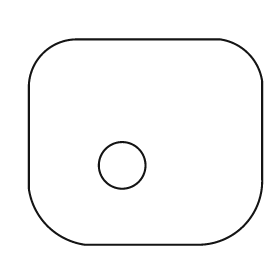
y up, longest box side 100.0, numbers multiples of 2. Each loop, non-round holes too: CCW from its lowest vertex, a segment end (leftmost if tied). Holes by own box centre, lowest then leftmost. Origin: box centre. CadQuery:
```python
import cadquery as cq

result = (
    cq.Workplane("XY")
    .moveTo(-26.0, -44.0)
    .lineTo(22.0, -44.0)
    .threePointArc((42.0, -36.0), (50.0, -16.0))
    .lineTo(50.0, 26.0)
    .threePointArc((44.0, 38.0), (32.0, 44.0))
    .lineTo(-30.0, 44.0)
    .threePointArc((-44.0, 38.0), (-50.0, 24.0))
    .lineTo(-50.0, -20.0)
    .threePointArc((-42.0, -36.0), (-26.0, -44.0))
    .close()
    .moveTo(-10.0, -10.0)
    .circle(10.0)
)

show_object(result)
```